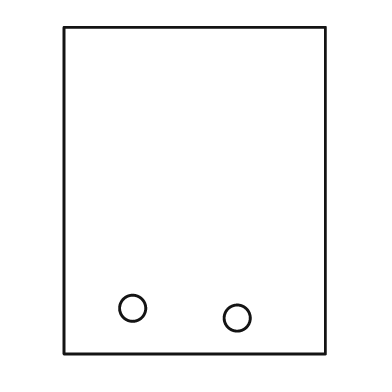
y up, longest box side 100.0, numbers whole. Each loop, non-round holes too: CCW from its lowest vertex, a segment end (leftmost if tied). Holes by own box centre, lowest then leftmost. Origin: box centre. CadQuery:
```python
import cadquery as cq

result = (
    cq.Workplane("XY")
    .moveTo(-40.0, -50.0)
    .lineTo(40.0, -50.0)
    .lineTo(40.0, 50.0)
    .lineTo(-40.0, 50.0)
    .close()
    .moveTo(13.0, -39.0)
    .circle(4.0)
    .moveTo(-19.0, -36.0)
    .circle(4.0)
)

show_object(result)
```